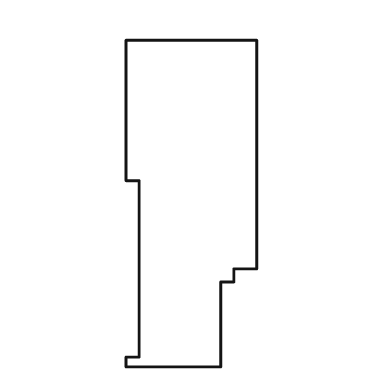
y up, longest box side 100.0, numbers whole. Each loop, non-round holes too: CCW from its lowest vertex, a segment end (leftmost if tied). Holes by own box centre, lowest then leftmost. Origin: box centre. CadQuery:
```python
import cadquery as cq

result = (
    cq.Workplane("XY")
    .moveTo(-20.0, -50.0)
    .lineTo(9.0, -50.0)
    .lineTo(9.0, -24.0)
    .lineTo(13.0, -24.0)
    .lineTo(13.0, -20.0)
    .lineTo(20.0, -20.0)
    .lineTo(20.0, 50.0)
    .lineTo(-20.0, 50.0)
    .lineTo(-20.0, 7.0)
    .lineTo(-16.0, 7.0)
    .lineTo(-16.0, -47.0)
    .lineTo(-20.0, -47.0)
    .close()
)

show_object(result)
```